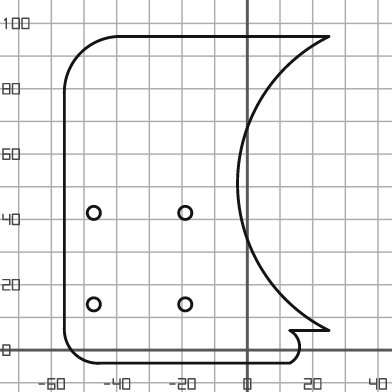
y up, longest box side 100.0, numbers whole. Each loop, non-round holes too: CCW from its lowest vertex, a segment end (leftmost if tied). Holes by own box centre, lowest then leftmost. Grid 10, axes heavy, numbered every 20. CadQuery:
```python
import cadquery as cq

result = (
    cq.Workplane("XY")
    .moveTo(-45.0, -4.0)
    .lineTo(13.0, -4.0)
    .threePointArc((16.0, 1.0), (13.0, 6.0))
    .lineTo(25.0, 6.0)
    .threePointArc((-3.0, 51.0), (25.0, 96.0))
    .lineTo(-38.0, 96.0)
    .threePointArc((-51.0, 91.0), (-56.0, 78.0))
    .lineTo(-56.0, 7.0)
    .threePointArc((-53.0, -1.0), (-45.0, -4.0))
    .close()
    .moveTo(-47.0, 14.0)
    .circle(2.0)
    .moveTo(-19.0, 14.0)
    .circle(2.0)
    .moveTo(-47.0, 42.0)
    .circle(2.0)
    .moveTo(-19.0, 42.0)
    .circle(2.0)
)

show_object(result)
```